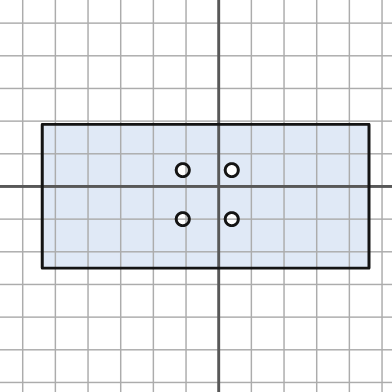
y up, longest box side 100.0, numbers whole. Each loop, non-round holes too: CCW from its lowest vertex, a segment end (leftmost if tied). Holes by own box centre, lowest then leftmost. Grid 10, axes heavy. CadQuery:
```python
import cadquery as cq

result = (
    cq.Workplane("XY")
    .moveTo(-54.0, -25.0)
    .lineTo(46.0, -25.0)
    .lineTo(46.0, 19.0)
    .lineTo(-54.0, 19.0)
    .close()
    .moveTo(-11.0, -10.0)
    .circle(2.0)
    .moveTo(4.0, -10.0)
    .circle(2.0)
    .moveTo(-11.0, 5.0)
    .circle(2.0)
    .moveTo(4.0, 5.0)
    .circle(2.0)
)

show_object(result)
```